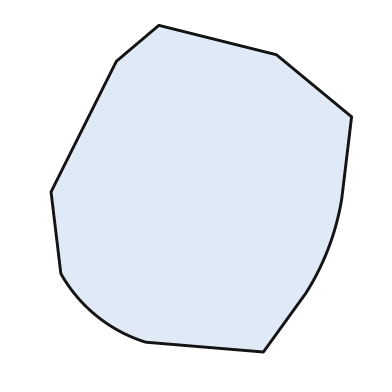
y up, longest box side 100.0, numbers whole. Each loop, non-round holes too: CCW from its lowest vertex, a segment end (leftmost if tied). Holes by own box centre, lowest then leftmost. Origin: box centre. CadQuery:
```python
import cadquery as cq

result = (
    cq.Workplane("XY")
    .moveTo(19.0, -50.0)
    .lineTo(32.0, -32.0)
    .threePointArc((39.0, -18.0), (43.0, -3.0))
    .lineTo(46.0, 22.0)
    .lineTo(23.0, 41.0)
    .lineTo(-13.0, 50.0)
    .lineTo(-26.0, 39.0)
    .lineTo(-46.0, -1.0)
    .lineTo(-43.0, -26.0)
    .threePointArc((-32.0, -39.0), (-17.0, -47.0))
    .close()
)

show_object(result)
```